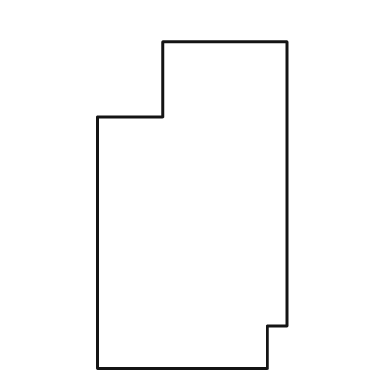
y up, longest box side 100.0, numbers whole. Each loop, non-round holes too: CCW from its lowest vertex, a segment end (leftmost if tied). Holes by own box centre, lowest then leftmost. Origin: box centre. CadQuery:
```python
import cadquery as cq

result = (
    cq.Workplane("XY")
    .moveTo(-29.0, -50.0)
    .lineTo(23.0, -50.0)
    .lineTo(23.0, -37.0)
    .lineTo(29.0, -37.0)
    .lineTo(29.0, 50.0)
    .lineTo(-9.0, 50.0)
    .lineTo(-9.0, 27.0)
    .lineTo(-29.0, 27.0)
    .close()
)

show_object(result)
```